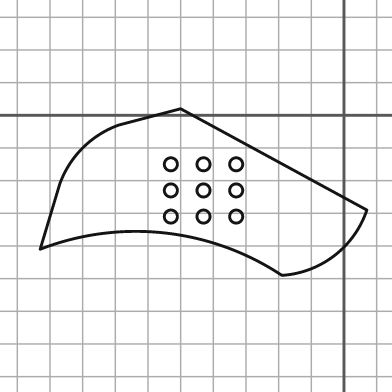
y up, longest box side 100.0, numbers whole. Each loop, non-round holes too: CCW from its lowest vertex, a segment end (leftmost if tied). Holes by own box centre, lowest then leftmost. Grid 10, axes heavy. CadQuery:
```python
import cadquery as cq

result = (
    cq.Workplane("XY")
    .moveTo(-19.0, -49.0)
    .threePointArc((-3.0, -43.0), (7.0, -29.0))
    .lineTo(-50.0, 2.0)
    .lineTo(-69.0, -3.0)
    .threePointArc((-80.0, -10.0), (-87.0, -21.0))
    .lineTo(-93.0, -41.0)
    .threePointArc((-55.0, -36.0), (-19.0, -49.0))
    .close()
    .moveTo(-53.0, -31.0)
    .circle(2.0)
    .moveTo(-43.0, -31.0)
    .circle(2.0)
    .moveTo(-33.0, -31.0)
    .circle(2.0)
    .moveTo(-53.0, -23.0)
    .circle(2.0)
    .moveTo(-43.0, -23.0)
    .circle(2.0)
    .moveTo(-33.0, -23.0)
    .circle(2.0)
    .moveTo(-53.0, -15.0)
    .circle(2.0)
    .moveTo(-43.0, -15.0)
    .circle(2.0)
    .moveTo(-33.0, -15.0)
    .circle(2.0)
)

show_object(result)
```